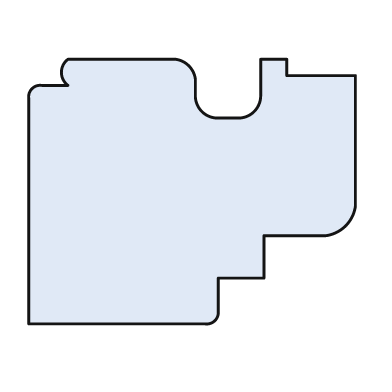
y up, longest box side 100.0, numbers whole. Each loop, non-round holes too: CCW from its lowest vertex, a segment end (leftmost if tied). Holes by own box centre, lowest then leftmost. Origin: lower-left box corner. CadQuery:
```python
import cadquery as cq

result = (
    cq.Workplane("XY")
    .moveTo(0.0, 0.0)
    .lineTo(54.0, 0.0)
    .threePointArc((57.0, 1.0), (58.0, 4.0))
    .lineTo(58.0, 14.0)
    .lineTo(72.0, 14.0)
    .lineTo(72.0, 27.0)
    .lineTo(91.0, 27.0)
    .threePointArc((97.0, 30.0), (100.0, 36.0))
    .lineTo(100.0, 76.0)
    .lineTo(79.0, 76.0)
    .lineTo(79.0, 81.0)
    .lineTo(71.0, 81.0)
    .lineTo(71.0, 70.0)
    .threePointArc((69.0, 65.0), (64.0, 63.0))
    .lineTo(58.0, 63.0)
    .threePointArc((53.0, 65.0), (51.0, 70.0))
    .lineTo(51.0, 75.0)
    .threePointArc((49.0, 79.0), (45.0, 81.0))
    .lineTo(12.0, 81.0)
    .threePointArc((10.0, 77.0), (12.0, 73.0))
    .lineTo(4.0, 73.0)
    .threePointArc((1.0, 72.0), (0.0, 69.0))
    .close()
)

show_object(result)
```